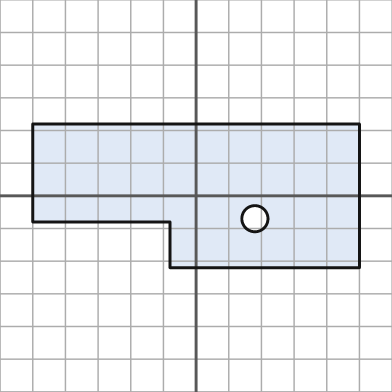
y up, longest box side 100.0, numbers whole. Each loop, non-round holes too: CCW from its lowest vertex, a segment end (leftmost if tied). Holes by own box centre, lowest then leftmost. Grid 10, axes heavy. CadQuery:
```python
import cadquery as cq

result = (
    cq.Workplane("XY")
    .moveTo(-8.0, -22.0)
    .lineTo(50.0, -22.0)
    .lineTo(50.0, 22.0)
    .lineTo(-50.0, 22.0)
    .lineTo(-50.0, -8.0)
    .lineTo(-8.0, -8.0)
    .close()
    .moveTo(18.0, -7.0)
    .circle(4.0)
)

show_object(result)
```